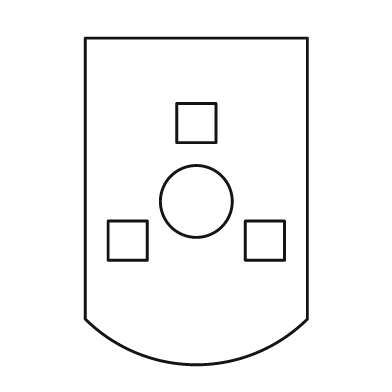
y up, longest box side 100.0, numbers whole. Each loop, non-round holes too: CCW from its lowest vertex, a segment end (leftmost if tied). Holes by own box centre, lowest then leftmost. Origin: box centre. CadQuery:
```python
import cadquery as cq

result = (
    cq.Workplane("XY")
    .moveTo(-34.0, -36.0)
    .threePointArc((0.0, -50.0), (34.0, -36.0))
    .lineTo(34.0, 50.0)
    .lineTo(-34.0, 50.0)
    .close()
    .moveTo(-27.0, -18.0)
    .lineTo(-15.0, -18.0)
    .lineTo(-15.0, -6.0)
    .lineTo(-27.0, -6.0)
    .close()
    .moveTo(15.0, -18.0)
    .lineTo(27.0, -18.0)
    .lineTo(27.0, -6.0)
    .lineTo(15.0, -6.0)
    .close()
    .moveTo(0.0, 0.0)
    .circle(11.0)
    .moveTo(-6.0, 18.0)
    .lineTo(6.0, 18.0)
    .lineTo(6.0, 30.0)
    .lineTo(-6.0, 30.0)
    .close()
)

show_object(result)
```